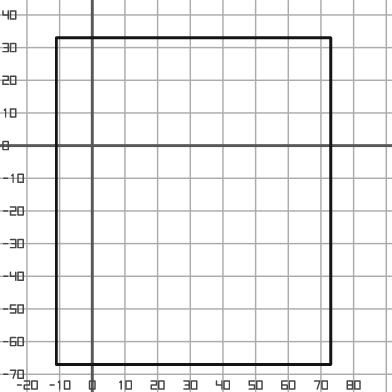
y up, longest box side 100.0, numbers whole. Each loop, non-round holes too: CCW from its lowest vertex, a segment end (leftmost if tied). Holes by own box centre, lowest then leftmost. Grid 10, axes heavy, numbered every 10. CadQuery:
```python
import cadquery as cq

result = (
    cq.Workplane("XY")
    .moveTo(-11.0, -67.0)
    .lineTo(73.0, -67.0)
    .lineTo(73.0, 33.0)
    .lineTo(-11.0, 33.0)
    .close()
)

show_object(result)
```